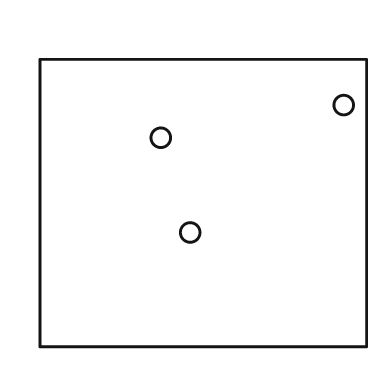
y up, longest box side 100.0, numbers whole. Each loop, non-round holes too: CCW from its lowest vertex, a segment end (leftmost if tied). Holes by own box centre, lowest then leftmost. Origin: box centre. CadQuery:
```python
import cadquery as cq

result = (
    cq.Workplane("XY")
    .moveTo(-50.0, -44.0)
    .lineTo(50.0, -44.0)
    .lineTo(50.0, 44.0)
    .lineTo(-50.0, 44.0)
    .close()
    .moveTo(-4.0, -9.0)
    .circle(3.0)
    .moveTo(-13.0, 20.0)
    .circle(3.0)
    .moveTo(43.0, 30.0)
    .circle(3.0)
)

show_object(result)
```